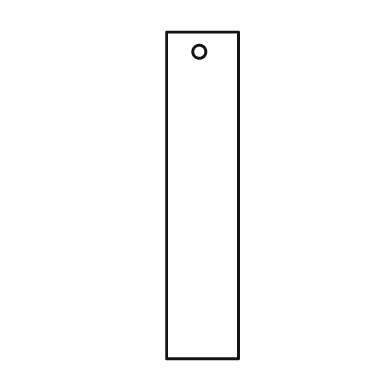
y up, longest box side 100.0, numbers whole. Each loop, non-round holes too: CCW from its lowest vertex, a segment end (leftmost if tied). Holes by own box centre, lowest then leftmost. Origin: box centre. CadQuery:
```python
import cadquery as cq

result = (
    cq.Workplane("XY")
    .moveTo(-11.0, -50.0)
    .lineTo(11.0, -50.0)
    .lineTo(11.0, 50.0)
    .lineTo(-11.0, 50.0)
    .close()
    .moveTo(-1.0, 44.0)
    .circle(2.0)
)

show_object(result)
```